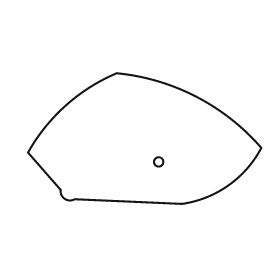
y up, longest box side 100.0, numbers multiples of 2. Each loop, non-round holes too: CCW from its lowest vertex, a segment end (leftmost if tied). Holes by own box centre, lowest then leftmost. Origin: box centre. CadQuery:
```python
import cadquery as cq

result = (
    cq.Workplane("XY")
    .moveTo(16.0, -28.0)
    .threePointArc((36.0, -20.0), (50.0, -4.0))
    .threePointArc((22.0, 18.0), (-12.0, 28.0))
    .threePointArc((-34.0, 14.0), (-50.0, -6.0))
    .lineTo(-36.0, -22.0)
    .threePointArc((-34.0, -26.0), (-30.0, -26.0))
    .close()
    .moveTo(6.0, -10.0)
    .circle(2.0)
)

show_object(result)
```